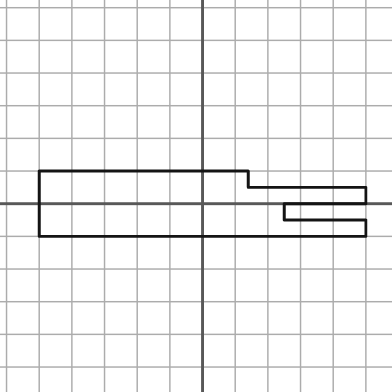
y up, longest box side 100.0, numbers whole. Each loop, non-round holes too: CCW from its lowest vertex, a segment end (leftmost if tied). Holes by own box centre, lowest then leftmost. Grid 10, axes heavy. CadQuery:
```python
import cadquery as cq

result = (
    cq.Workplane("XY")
    .moveTo(-50.0, -10.0)
    .lineTo(50.0, -10.0)
    .lineTo(50.0, -5.0)
    .lineTo(25.0, -5.0)
    .lineTo(25.0, 0.0)
    .lineTo(50.0, 0.0)
    .lineTo(50.0, 5.0)
    .lineTo(14.0, 5.0)
    .lineTo(14.0, 10.0)
    .lineTo(-50.0, 10.0)
    .close()
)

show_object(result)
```